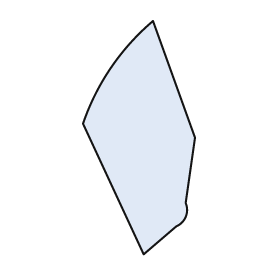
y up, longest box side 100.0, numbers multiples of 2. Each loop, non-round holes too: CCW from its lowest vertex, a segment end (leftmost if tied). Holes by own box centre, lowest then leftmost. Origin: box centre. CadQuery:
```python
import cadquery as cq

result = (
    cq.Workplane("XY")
    .moveTo(2.0, -50.0)
    .lineTo(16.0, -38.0)
    .threePointArc((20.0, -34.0), (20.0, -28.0))
    .lineTo(24.0, 0.0)
    .lineTo(6.0, 50.0)
    .threePointArc((-12.0, 30.0), (-24.0, 6.0))
    .close()
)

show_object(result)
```